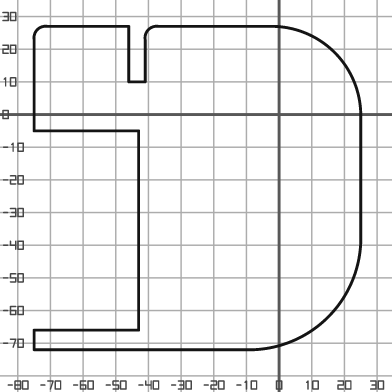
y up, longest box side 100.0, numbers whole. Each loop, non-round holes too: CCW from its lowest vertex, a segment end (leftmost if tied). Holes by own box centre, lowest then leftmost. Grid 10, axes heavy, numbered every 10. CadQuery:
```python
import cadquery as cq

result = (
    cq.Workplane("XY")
    .moveTo(-75.0, -72.0)
    .lineTo(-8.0, -72.0)
    .threePointArc((15.0, -62.0), (25.0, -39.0))
    .lineTo(25.0, 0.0)
    .threePointArc((17.0, 19.0), (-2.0, 27.0))
    .lineTo(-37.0, 27.0)
    .threePointArc((-40.0, 26.0), (-41.0, 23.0))
    .lineTo(-41.0, 10.0)
    .lineTo(-46.0, 10.0)
    .lineTo(-46.0, 27.0)
    .lineTo(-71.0, 27.0)
    .threePointArc((-74.0, 26.0), (-75.0, 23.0))
    .lineTo(-75.0, -5.0)
    .lineTo(-43.0, -5.0)
    .lineTo(-43.0, -66.0)
    .lineTo(-75.0, -66.0)
    .close()
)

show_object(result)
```